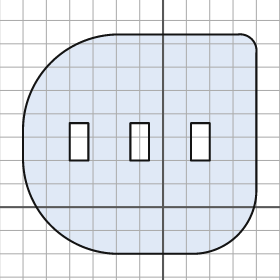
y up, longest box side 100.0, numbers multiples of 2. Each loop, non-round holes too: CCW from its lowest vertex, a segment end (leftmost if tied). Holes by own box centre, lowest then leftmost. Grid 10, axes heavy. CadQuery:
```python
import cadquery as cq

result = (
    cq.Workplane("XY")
    .moveTo(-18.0, -20.0)
    .lineTo(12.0, -20.0)
    .threePointArc((32.0, -12.0), (40.0, 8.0))
    .lineTo(40.0, 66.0)
    .threePointArc((38.0, 72.0), (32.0, 74.0))
    .lineTo(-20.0, 74.0)
    .threePointArc((-48.0, 62.0), (-60.0, 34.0))
    .lineTo(-60.0, 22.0)
    .threePointArc((-48.0, -8.0), (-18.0, -20.0))
    .close()
    .moveTo(-40.0, 20.0)
    .lineTo(-32.0, 20.0)
    .lineTo(-32.0, 36.0)
    .lineTo(-40.0, 36.0)
    .close()
    .moveTo(-14.0, 20.0)
    .lineTo(-6.0, 20.0)
    .lineTo(-6.0, 36.0)
    .lineTo(-14.0, 36.0)
    .close()
    .moveTo(12.0, 20.0)
    .lineTo(20.0, 20.0)
    .lineTo(20.0, 36.0)
    .lineTo(12.0, 36.0)
    .close()
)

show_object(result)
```